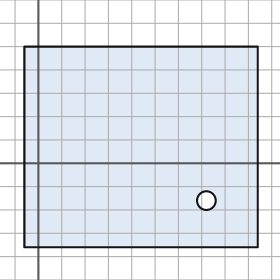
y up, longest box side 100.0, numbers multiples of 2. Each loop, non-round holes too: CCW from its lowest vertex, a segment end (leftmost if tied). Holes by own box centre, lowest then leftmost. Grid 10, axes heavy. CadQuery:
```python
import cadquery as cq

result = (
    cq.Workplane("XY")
    .moveTo(-6.0, -36.0)
    .lineTo(94.0, -36.0)
    .lineTo(94.0, 50.0)
    .lineTo(-6.0, 50.0)
    .close()
    .moveTo(72.0, -16.0)
    .circle(4.0)
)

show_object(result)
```